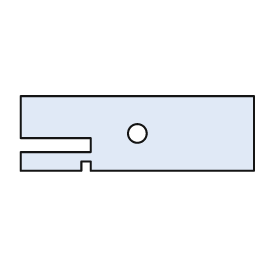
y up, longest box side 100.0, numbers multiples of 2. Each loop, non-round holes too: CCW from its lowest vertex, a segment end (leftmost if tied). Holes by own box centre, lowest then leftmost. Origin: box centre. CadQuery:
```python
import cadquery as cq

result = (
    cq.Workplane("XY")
    .moveTo(-50.0, -16.0)
    .lineTo(-24.0, -16.0)
    .lineTo(-24.0, -12.0)
    .lineTo(-20.0, -12.0)
    .lineTo(-20.0, -16.0)
    .lineTo(50.0, -16.0)
    .lineTo(50.0, 16.0)
    .lineTo(-50.0, 16.0)
    .lineTo(-50.0, -2.0)
    .lineTo(-20.0, -2.0)
    .lineTo(-20.0, -8.0)
    .lineTo(-50.0, -8.0)
    .close()
    .moveTo(0.0, 0.0)
    .circle(4.0)
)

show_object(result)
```